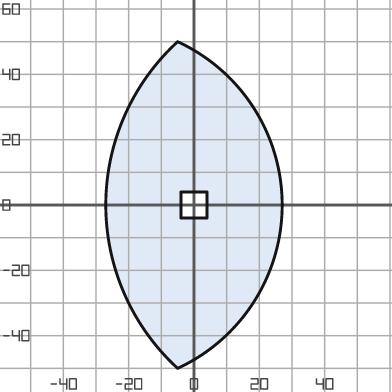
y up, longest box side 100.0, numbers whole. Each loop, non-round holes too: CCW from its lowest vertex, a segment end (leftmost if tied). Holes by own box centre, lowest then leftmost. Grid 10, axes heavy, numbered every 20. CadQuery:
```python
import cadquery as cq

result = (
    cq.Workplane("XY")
    .moveTo(-5.0, -50.0)
    .threePointArc((27.0, 0.0), (-5.0, 50.0))
    .threePointArc((-27.0, 0.0), (-5.0, -50.0))
    .close()
    .moveTo(-4.0, -4.0)
    .lineTo(4.0, -4.0)
    .lineTo(4.0, 4.0)
    .lineTo(-4.0, 4.0)
    .close()
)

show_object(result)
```